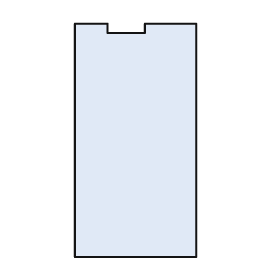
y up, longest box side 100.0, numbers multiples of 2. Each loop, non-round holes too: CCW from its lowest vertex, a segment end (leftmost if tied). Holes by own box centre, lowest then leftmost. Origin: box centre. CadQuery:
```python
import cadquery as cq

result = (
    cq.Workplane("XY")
    .moveTo(-26.0, -50.0)
    .lineTo(26.0, -50.0)
    .lineTo(26.0, 50.0)
    .lineTo(4.0, 50.0)
    .lineTo(4.0, 46.0)
    .lineTo(-12.0, 46.0)
    .lineTo(-12.0, 50.0)
    .lineTo(-26.0, 50.0)
    .close()
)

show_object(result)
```